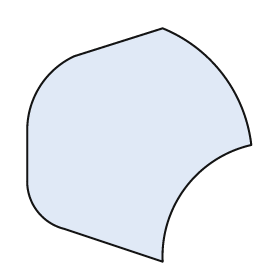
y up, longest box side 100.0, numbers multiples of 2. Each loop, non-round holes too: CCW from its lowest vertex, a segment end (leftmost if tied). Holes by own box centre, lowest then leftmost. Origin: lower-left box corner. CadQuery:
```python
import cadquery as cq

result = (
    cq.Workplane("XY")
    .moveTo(58.0, 0.0)
    .threePointArc((68.0, 32.0), (96.0, 50.0))
    .threePointArc((84.0, 80.0), (58.0, 100.0))
    .lineTo(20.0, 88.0)
    .threePointArc((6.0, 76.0), (0.0, 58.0))
    .lineTo(0.0, 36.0)
    .threePointArc((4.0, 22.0), (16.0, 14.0))
    .close()
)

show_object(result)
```